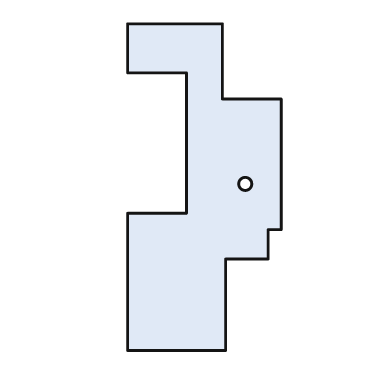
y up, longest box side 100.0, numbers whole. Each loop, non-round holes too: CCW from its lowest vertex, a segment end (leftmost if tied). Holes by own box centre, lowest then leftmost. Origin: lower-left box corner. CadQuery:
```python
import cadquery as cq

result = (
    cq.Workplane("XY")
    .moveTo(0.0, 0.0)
    .lineTo(30.0, 0.0)
    .lineTo(30.0, 28.0)
    .lineTo(43.0, 28.0)
    .lineTo(43.0, 37.0)
    .lineTo(47.0, 37.0)
    .lineTo(47.0, 77.0)
    .lineTo(29.0, 77.0)
    .lineTo(29.0, 100.0)
    .lineTo(0.0, 100.0)
    .lineTo(0.0, 85.0)
    .lineTo(18.0, 85.0)
    .lineTo(18.0, 42.0)
    .lineTo(0.0, 42.0)
    .close()
    .moveTo(36.0, 51.0)
    .circle(2.0)
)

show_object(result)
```